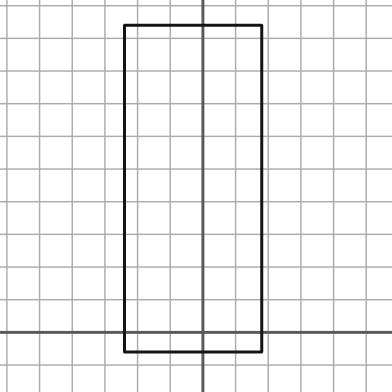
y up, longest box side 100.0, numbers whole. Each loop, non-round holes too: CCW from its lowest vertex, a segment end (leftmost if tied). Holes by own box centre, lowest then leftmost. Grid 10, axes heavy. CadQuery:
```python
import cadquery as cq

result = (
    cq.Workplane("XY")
    .moveTo(-24.0, -6.0)
    .lineTo(18.0, -6.0)
    .lineTo(18.0, 94.0)
    .lineTo(-24.0, 94.0)
    .close()
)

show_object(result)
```